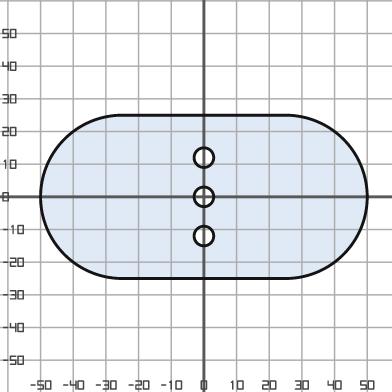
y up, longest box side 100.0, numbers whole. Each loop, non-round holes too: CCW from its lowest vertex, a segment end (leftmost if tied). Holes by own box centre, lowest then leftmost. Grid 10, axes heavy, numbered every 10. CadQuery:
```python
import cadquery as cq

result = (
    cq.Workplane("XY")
    .moveTo(-25.0, -25.0)
    .lineTo(25.0, -25.0)
    .threePointArc((50.0, 0.0), (25.0, 25.0))
    .lineTo(-25.0, 25.0)
    .threePointArc((-50.0, 0.0), (-25.0, -25.0))
    .close()
    .moveTo(0.0, -12.0)
    .circle(3.0)
    .moveTo(0.0, 0.0)
    .circle(3.0)
    .moveTo(0.0, 12.0)
    .circle(3.0)
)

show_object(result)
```